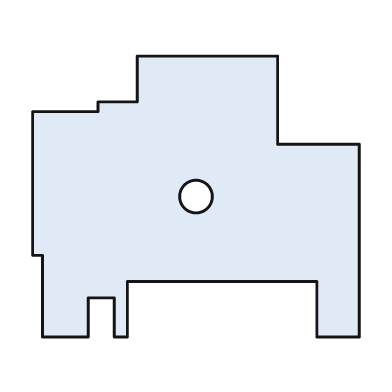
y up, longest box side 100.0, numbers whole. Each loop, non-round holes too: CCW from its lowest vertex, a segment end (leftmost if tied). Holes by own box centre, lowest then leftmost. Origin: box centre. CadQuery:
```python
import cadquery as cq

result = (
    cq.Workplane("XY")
    .moveTo(-47.0, -43.0)
    .lineTo(-33.0, -43.0)
    .lineTo(-33.0, -31.0)
    .lineTo(-25.0, -31.0)
    .lineTo(-25.0, -43.0)
    .lineTo(-21.0, -43.0)
    .lineTo(-21.0, -26.0)
    .lineTo(37.0, -26.0)
    .lineTo(37.0, -43.0)
    .lineTo(50.0, -43.0)
    .lineTo(50.0, 16.0)
    .lineTo(25.0, 16.0)
    .lineTo(25.0, 43.0)
    .lineTo(-18.0, 43.0)
    .lineTo(-18.0, 29.0)
    .lineTo(-30.0, 29.0)
    .lineTo(-30.0, 26.0)
    .lineTo(-50.0, 26.0)
    .lineTo(-50.0, -18.0)
    .lineTo(-47.0, -18.0)
    .close()
    .moveTo(0.0, 0.0)
    .circle(5.0)
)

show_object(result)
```